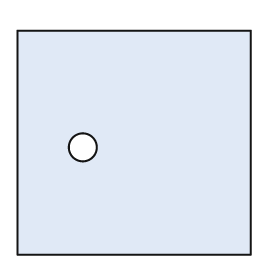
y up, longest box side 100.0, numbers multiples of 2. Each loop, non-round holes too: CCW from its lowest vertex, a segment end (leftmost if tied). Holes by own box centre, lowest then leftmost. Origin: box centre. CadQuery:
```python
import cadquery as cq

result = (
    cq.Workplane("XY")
    .moveTo(-50.0, -48.0)
    .lineTo(50.0, -48.0)
    .lineTo(50.0, 48.0)
    .lineTo(-50.0, 48.0)
    .close()
    .moveTo(-22.0, -2.0)
    .circle(6.0)
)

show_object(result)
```